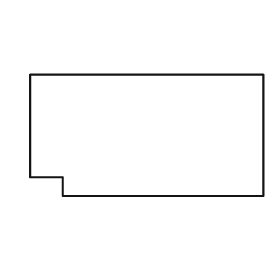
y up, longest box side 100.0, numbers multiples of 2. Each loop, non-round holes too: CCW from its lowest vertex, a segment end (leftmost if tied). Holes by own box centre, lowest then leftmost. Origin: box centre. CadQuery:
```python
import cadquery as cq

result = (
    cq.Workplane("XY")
    .moveTo(-36.0, -26.0)
    .lineTo(50.0, -26.0)
    .lineTo(50.0, 26.0)
    .lineTo(-50.0, 26.0)
    .lineTo(-50.0, -18.0)
    .lineTo(-36.0, -18.0)
    .close()
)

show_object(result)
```